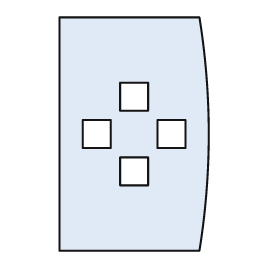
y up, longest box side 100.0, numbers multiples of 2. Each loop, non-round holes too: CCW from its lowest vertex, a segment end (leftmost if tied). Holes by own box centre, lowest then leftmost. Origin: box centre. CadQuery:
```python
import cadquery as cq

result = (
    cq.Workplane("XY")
    .moveTo(-32.0, -50.0)
    .lineTo(28.0, -50.0)
    .threePointArc((32.0, 0.0), (28.0, 50.0))
    .lineTo(-32.0, 50.0)
    .close()
    .moveTo(-6.0, -22.0)
    .lineTo(6.0, -22.0)
    .lineTo(6.0, -10.0)
    .lineTo(-6.0, -10.0)
    .close()
    .moveTo(-22.0, -6.0)
    .lineTo(-10.0, -6.0)
    .lineTo(-10.0, 6.0)
    .lineTo(-22.0, 6.0)
    .close()
    .moveTo(10.0, -6.0)
    .lineTo(22.0, -6.0)
    .lineTo(22.0, 6.0)
    .lineTo(10.0, 6.0)
    .close()
    .moveTo(-6.0, 10.0)
    .lineTo(6.0, 10.0)
    .lineTo(6.0, 22.0)
    .lineTo(-6.0, 22.0)
    .close()
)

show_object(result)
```